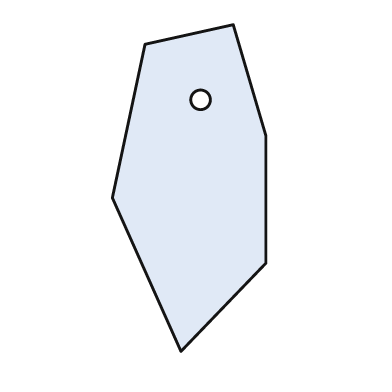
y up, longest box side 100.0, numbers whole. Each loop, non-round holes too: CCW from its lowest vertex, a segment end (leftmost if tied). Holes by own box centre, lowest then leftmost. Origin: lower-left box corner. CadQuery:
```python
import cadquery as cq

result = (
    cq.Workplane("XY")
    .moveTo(21.0, 0.0)
    .lineTo(47.0, 27.0)
    .lineTo(47.0, 66.0)
    .lineTo(37.0, 100.0)
    .lineTo(10.0, 94.0)
    .lineTo(0.0, 47.0)
    .close()
    .moveTo(27.0, 77.0)
    .circle(3.0)
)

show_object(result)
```